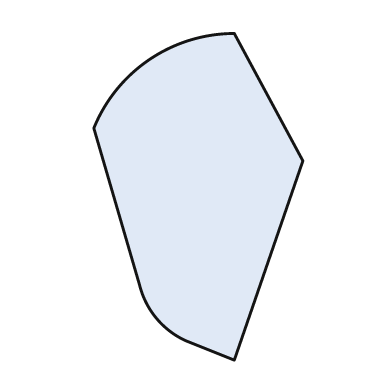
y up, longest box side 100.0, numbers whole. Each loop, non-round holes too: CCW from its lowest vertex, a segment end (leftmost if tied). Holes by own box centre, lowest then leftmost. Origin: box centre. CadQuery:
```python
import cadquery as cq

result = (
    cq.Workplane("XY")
    .moveTo(11.0, -50.0)
    .lineTo(32.0, 11.0)
    .lineTo(11.0, 50.0)
    .threePointArc((-15.0, 42.0), (-32.0, 21.0))
    .lineTo(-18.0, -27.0)
    .threePointArc((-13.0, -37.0), (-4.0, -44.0))
    .close()
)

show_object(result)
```